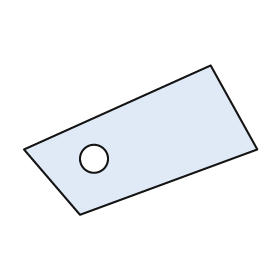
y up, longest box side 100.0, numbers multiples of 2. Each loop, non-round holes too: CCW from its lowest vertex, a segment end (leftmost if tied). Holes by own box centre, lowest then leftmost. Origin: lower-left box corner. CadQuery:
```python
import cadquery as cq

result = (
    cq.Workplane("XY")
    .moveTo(24.0, 0.0)
    .lineTo(100.0, 28.0)
    .lineTo(80.0, 64.0)
    .lineTo(0.0, 28.0)
    .close()
    .moveTo(30.0, 24.0)
    .circle(6.0)
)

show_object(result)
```